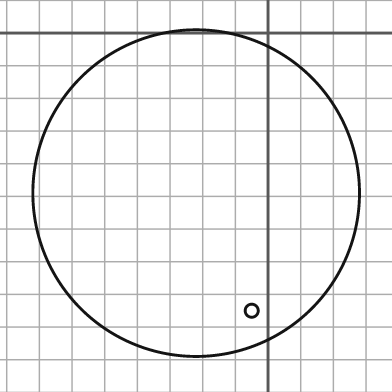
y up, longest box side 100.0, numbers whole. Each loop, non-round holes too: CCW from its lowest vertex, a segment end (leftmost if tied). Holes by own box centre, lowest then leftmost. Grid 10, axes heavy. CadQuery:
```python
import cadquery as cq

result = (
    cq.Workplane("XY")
    .moveTo(-22.0, -49.0)
    .circle(50.0)
    .moveTo(-5.0, -85.0)
    .circle(2.0)
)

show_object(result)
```